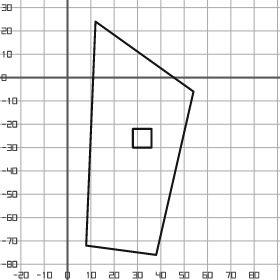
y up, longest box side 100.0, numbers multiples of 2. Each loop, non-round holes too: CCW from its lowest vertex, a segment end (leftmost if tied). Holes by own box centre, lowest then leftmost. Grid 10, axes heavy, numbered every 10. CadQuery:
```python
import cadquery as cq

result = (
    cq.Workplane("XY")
    .moveTo(38.0, -76.0)
    .lineTo(54.0, -6.0)
    .lineTo(12.0, 24.0)
    .lineTo(8.0, -72.0)
    .close()
    .moveTo(28.0, -30.0)
    .lineTo(36.0, -30.0)
    .lineTo(36.0, -22.0)
    .lineTo(28.0, -22.0)
    .close()
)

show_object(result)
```